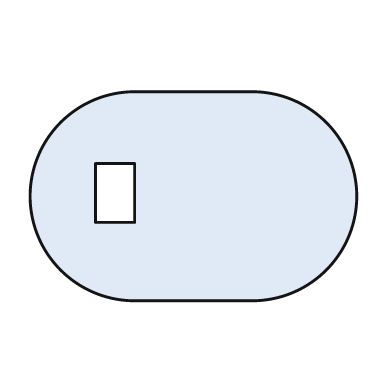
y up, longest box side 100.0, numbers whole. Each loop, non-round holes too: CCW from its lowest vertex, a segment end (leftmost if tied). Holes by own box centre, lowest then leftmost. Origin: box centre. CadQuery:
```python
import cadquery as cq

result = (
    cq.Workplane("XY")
    .moveTo(-18.0, -32.0)
    .lineTo(18.0, -32.0)
    .threePointArc((50.0, 0.0), (18.0, 32.0))
    .lineTo(-18.0, 32.0)
    .threePointArc((-50.0, 0.0), (-18.0, -32.0))
    .close()
    .moveTo(-30.0, -8.0)
    .lineTo(-18.0, -8.0)
    .lineTo(-18.0, 10.0)
    .lineTo(-30.0, 10.0)
    .close()
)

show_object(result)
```